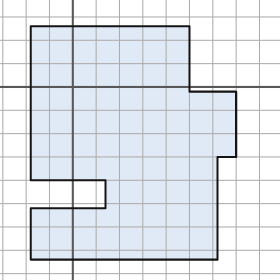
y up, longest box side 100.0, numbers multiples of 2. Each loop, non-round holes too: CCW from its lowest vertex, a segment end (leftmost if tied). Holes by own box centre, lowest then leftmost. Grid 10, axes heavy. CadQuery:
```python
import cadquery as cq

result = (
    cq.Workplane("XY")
    .moveTo(-18.0, -74.0)
    .lineTo(62.0, -74.0)
    .lineTo(62.0, -30.0)
    .lineTo(70.0, -30.0)
    .lineTo(70.0, -2.0)
    .lineTo(50.0, -2.0)
    .lineTo(50.0, 26.0)
    .lineTo(-18.0, 26.0)
    .lineTo(-18.0, -40.0)
    .lineTo(14.0, -40.0)
    .lineTo(14.0, -52.0)
    .lineTo(-18.0, -52.0)
    .close()
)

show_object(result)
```